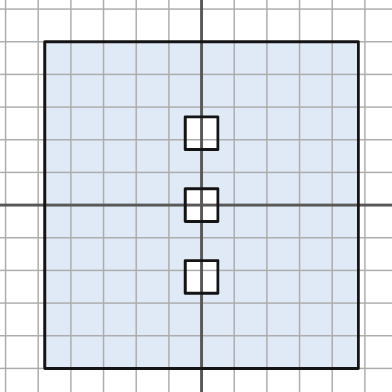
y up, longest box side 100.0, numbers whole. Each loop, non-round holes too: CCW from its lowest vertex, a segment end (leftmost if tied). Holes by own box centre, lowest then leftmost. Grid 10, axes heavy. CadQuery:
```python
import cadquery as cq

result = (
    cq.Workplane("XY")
    .moveTo(-48.0, -50.0)
    .lineTo(48.0, -50.0)
    .lineTo(48.0, 50.0)
    .lineTo(-48.0, 50.0)
    .close()
    .moveTo(-5.0, -27.0)
    .lineTo(5.0, -27.0)
    .lineTo(5.0, -17.0)
    .lineTo(-5.0, -17.0)
    .close()
    .moveTo(-5.0, -5.0)
    .lineTo(5.0, -5.0)
    .lineTo(5.0, 5.0)
    .lineTo(-5.0, 5.0)
    .close()
    .moveTo(-5.0, 17.0)
    .lineTo(5.0, 17.0)
    .lineTo(5.0, 27.0)
    .lineTo(-5.0, 27.0)
    .close()
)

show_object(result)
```